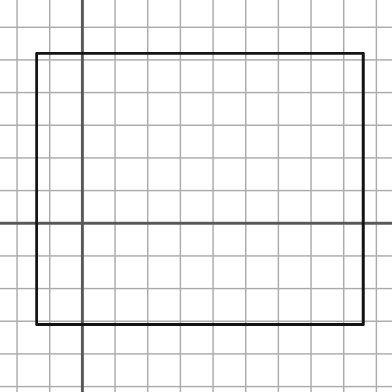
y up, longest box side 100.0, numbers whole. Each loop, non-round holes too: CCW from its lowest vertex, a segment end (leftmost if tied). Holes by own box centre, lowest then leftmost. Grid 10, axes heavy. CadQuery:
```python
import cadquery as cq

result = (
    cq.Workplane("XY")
    .moveTo(-14.0, -31.0)
    .lineTo(86.0, -31.0)
    .lineTo(86.0, 52.0)
    .lineTo(-14.0, 52.0)
    .close()
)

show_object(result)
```